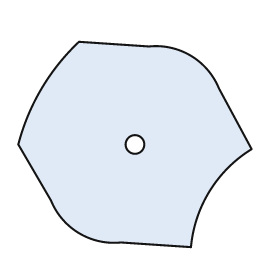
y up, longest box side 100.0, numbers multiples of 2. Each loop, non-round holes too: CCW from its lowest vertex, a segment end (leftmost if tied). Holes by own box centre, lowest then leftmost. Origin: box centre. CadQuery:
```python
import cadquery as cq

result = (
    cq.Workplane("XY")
    .moveTo(24.0, -44.0)
    .threePointArc((32.0, -20.0), (50.0, -2.0))
    .lineTo(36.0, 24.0)
    .threePointArc((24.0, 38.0), (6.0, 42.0))
    .lineTo(-24.0, 44.0)
    .threePointArc((-40.0, 24.0), (-50.0, 0.0))
    .lineTo(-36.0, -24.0)
    .threePointArc((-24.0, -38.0), (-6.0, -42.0))
    .close()
    .moveTo(0.0, 0.0)
    .circle(4.0)
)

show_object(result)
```